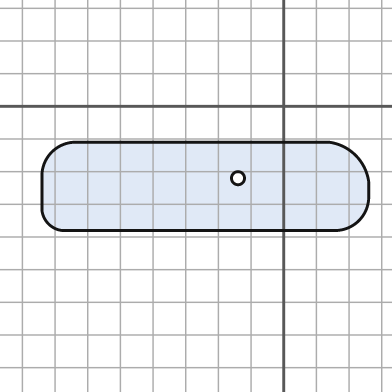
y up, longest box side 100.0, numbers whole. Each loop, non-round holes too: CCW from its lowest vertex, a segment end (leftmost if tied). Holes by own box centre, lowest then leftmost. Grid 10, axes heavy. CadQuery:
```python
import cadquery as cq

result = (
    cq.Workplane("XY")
    .moveTo(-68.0, -38.0)
    .lineTo(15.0, -38.0)
    .threePointArc((23.0, -35.0), (26.0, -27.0))
    .lineTo(26.0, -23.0)
    .threePointArc((22.0, -15.0), (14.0, -11.0))
    .lineTo(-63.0, -11.0)
    .threePointArc((-71.0, -14.0), (-74.0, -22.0))
    .lineTo(-74.0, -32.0)
    .threePointArc((-72.0, -36.0), (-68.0, -38.0))
    .close()
    .moveTo(-14.0, -22.0)
    .circle(2.0)
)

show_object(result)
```